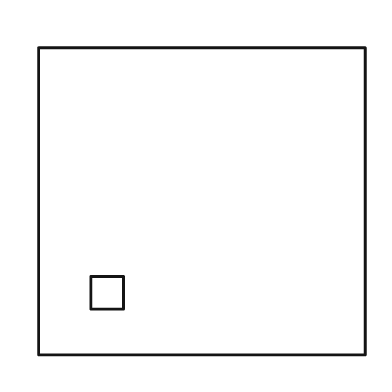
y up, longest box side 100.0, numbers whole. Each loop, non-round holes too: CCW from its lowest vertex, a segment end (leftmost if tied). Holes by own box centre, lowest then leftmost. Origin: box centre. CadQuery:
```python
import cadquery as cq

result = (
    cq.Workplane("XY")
    .moveTo(-50.0, -47.0)
    .lineTo(50.0, -47.0)
    .lineTo(50.0, 47.0)
    .lineTo(-50.0, 47.0)
    .close()
    .moveTo(-34.0, -33.0)
    .lineTo(-24.0, -33.0)
    .lineTo(-24.0, -23.0)
    .lineTo(-34.0, -23.0)
    .close()
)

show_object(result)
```